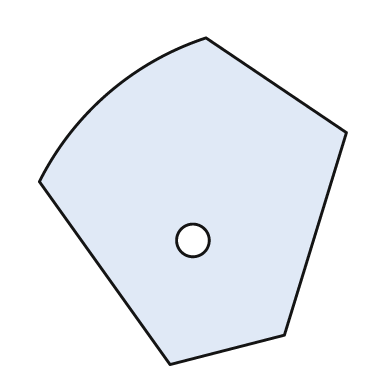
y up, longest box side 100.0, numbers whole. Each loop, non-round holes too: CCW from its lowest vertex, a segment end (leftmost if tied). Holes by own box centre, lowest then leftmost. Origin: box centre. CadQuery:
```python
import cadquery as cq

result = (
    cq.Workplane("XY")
    .moveTo(-7.0, -50.0)
    .lineTo(28.0, -41.0)
    .lineTo(47.0, 21.0)
    .lineTo(4.0, 50.0)
    .threePointArc((-26.0, 33.0), (-47.0, 6.0))
    .close()
    .moveTo(0.0, -12.0)
    .circle(5.0)
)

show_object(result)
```